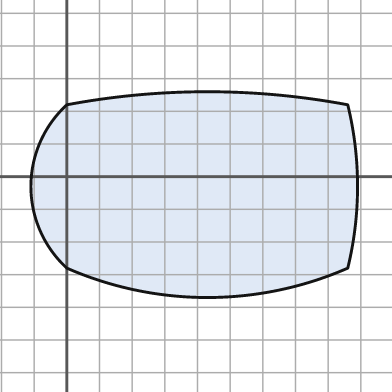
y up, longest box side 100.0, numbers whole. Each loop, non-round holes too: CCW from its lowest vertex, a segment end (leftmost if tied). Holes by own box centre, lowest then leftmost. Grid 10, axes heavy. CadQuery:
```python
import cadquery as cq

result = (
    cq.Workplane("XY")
    .moveTo(0.0, -28.0)
    .threePointArc((43.0, -37.0), (86.0, -28.0))
    .threePointArc((89.0, -3.0), (86.0, 22.0))
    .threePointArc((43.0, 26.0), (0.0, 22.0))
    .threePointArc((-11.0, -3.0), (0.0, -28.0))
    .close()
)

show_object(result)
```